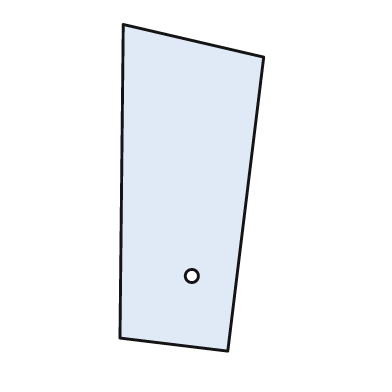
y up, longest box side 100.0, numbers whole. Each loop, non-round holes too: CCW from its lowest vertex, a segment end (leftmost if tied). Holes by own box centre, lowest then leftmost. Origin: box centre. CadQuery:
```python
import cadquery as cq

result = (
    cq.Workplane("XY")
    .moveTo(11.0, -50.0)
    .lineTo(22.0, 40.0)
    .lineTo(-21.0, 50.0)
    .lineTo(-22.0, -46.0)
    .close()
    .moveTo(0.0, -27.0)
    .circle(2.0)
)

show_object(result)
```